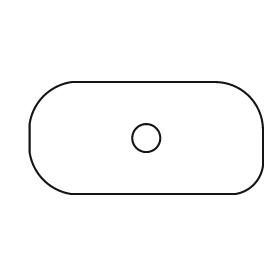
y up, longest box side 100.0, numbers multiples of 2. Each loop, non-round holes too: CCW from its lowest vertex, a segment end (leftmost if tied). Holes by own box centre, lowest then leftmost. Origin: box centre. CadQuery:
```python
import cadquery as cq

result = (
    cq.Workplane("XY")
    .moveTo(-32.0, -24.0)
    .lineTo(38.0, -24.0)
    .threePointArc((46.0, -20.0), (50.0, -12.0))
    .lineTo(50.0, 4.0)
    .threePointArc((44.0, 18.0), (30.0, 24.0))
    .lineTo(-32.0, 24.0)
    .threePointArc((-44.0, 18.0), (-50.0, 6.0))
    .lineTo(-50.0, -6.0)
    .threePointArc((-44.0, -18.0), (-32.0, -24.0))
    .close()
    .moveTo(0.0, 0.0)
    .circle(6.0)
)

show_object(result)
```